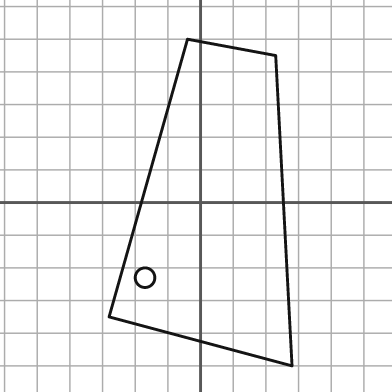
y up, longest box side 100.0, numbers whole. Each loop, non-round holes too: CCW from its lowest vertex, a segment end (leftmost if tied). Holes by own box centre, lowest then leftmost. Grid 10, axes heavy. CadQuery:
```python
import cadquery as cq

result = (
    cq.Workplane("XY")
    .moveTo(28.0, -50.0)
    .lineTo(23.0, 45.0)
    .lineTo(-4.0, 50.0)
    .lineTo(-28.0, -35.0)
    .close()
    .moveTo(-17.0, -23.0)
    .circle(3.0)
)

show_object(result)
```